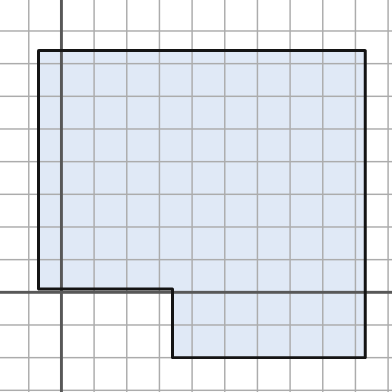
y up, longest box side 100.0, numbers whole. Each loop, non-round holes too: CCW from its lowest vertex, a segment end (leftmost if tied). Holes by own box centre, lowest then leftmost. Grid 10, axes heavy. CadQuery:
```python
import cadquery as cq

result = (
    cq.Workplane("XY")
    .moveTo(34.0, -20.0)
    .lineTo(93.0, -20.0)
    .lineTo(93.0, 74.0)
    .lineTo(-7.0, 74.0)
    .lineTo(-7.0, 1.0)
    .lineTo(34.0, 1.0)
    .close()
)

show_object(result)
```